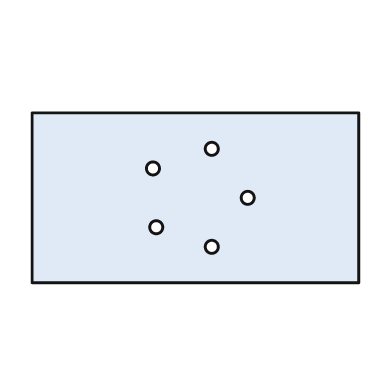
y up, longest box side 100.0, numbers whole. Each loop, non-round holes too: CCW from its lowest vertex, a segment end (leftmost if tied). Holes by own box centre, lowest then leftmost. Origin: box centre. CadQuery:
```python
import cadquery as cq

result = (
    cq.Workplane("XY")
    .moveTo(-50.0, -26.0)
    .lineTo(50.0, -26.0)
    .lineTo(50.0, 26.0)
    .lineTo(-50.0, 26.0)
    .close()
    .moveTo(5.0, -15.0)
    .circle(2.0)
    .moveTo(-12.0, -9.0)
    .circle(2.0)
    .moveTo(16.0, 0.0)
    .circle(2.0)
    .moveTo(-13.0, 9.0)
    .circle(2.0)
    .moveTo(5.0, 15.0)
    .circle(2.0)
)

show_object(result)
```